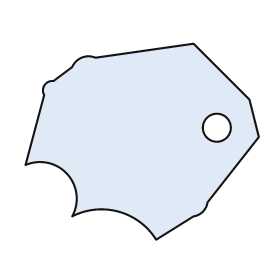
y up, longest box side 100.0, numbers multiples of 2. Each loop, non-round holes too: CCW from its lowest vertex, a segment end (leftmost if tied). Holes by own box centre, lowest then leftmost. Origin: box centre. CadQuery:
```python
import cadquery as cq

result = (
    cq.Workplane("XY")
    .moveTo(6.0, -42.0)
    .lineTo(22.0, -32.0)
    .threePointArc((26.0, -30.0), (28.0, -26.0))
    .lineTo(50.0, 2.0)
    .lineTo(46.0, 18.0)
    .lineTo(22.0, 42.0)
    .lineTo(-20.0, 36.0)
    .threePointArc((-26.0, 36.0), (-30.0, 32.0))
    .lineTo(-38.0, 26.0)
    .threePointArc((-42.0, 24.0), (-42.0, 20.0))
    .lineTo(-50.0, -10.0)
    .threePointArc((-32.0, -14.0), (-30.0, -32.0))
    .threePointArc((-10.0, -30.0), (6.0, -42.0))
    .close()
    .moveTo(32.0, 6.0)
    .circle(6.0)
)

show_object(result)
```